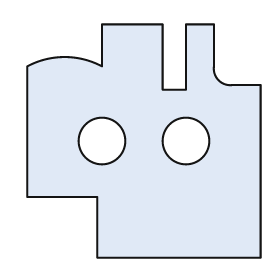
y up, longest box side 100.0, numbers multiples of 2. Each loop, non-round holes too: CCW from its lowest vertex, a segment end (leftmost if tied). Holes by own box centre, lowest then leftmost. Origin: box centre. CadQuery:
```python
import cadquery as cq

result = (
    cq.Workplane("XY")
    .moveTo(-20.0, -50.0)
    .lineTo(50.0, -50.0)
    .lineTo(50.0, 24.0)
    .lineTo(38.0, 24.0)
    .threePointArc((32.0, 26.0), (30.0, 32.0))
    .lineTo(30.0, 50.0)
    .lineTo(18.0, 50.0)
    .lineTo(18.0, 22.0)
    .lineTo(8.0, 22.0)
    .lineTo(8.0, 50.0)
    .lineTo(-18.0, 50.0)
    .lineTo(-18.0, 32.0)
    .threePointArc((-34.0, 36.0), (-50.0, 32.0))
    .lineTo(-50.0, -24.0)
    .lineTo(-20.0, -24.0)
    .close()
    .moveTo(-18.0, 0.0)
    .circle(10.0)
    .moveTo(18.0, 0.0)
    .circle(10.0)
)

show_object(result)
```